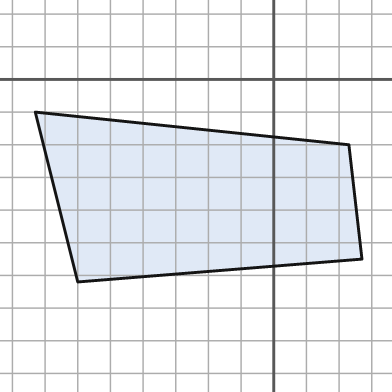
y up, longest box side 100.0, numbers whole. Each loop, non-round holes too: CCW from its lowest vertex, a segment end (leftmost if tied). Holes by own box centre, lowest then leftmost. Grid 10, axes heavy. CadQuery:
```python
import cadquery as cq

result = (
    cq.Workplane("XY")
    .moveTo(-60.0, -62.0)
    .lineTo(27.0, -55.0)
    .lineTo(23.0, -20.0)
    .lineTo(-73.0, -10.0)
    .close()
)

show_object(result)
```